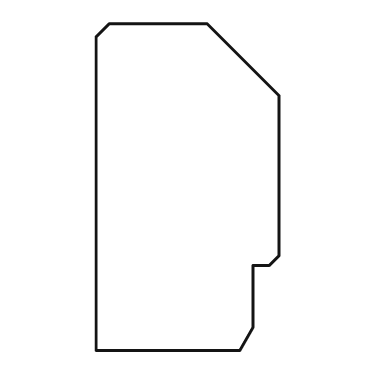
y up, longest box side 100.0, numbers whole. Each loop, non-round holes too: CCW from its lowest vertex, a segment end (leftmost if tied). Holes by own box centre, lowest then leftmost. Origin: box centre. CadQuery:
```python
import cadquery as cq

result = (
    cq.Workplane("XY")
    .moveTo(-28.0, -50.0)
    .lineTo(16.0, -50.0)
    .lineTo(20.0, -43.0)
    .lineTo(20.0, -24.0)
    .lineTo(25.0, -24.0)
    .lineTo(28.0, -21.0)
    .lineTo(28.0, 28.0)
    .lineTo(6.0, 50.0)
    .lineTo(-24.0, 50.0)
    .lineTo(-28.0, 46.0)
    .close()
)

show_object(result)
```